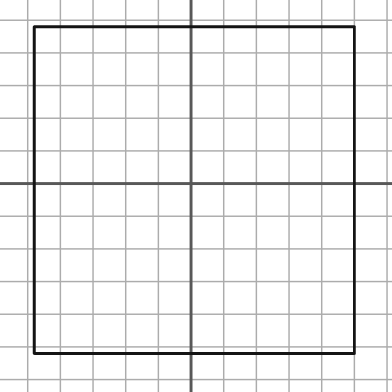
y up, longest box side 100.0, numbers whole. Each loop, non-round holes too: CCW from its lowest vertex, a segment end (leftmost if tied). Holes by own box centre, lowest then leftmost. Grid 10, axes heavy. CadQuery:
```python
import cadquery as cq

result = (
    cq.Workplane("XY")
    .moveTo(-48.0, -52.0)
    .lineTo(50.0, -52.0)
    .lineTo(50.0, 48.0)
    .lineTo(-48.0, 48.0)
    .close()
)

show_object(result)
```